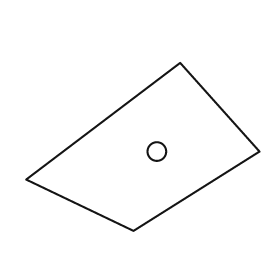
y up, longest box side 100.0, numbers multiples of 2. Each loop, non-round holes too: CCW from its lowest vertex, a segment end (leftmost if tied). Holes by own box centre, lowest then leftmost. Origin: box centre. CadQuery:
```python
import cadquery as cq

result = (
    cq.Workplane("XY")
    .moveTo(-4.0, -36.0)
    .lineTo(50.0, -2.0)
    .lineTo(16.0, 36.0)
    .lineTo(-50.0, -14.0)
    .close()
    .moveTo(6.0, -2.0)
    .circle(4.0)
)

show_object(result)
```